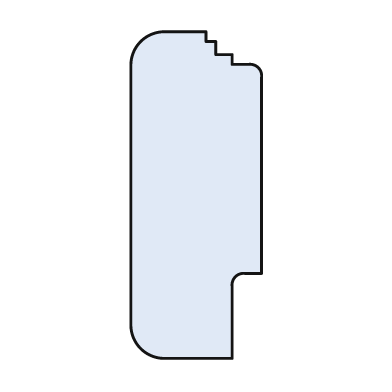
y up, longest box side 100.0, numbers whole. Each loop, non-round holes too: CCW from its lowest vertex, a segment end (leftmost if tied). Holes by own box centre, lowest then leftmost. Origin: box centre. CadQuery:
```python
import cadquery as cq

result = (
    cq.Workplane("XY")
    .moveTo(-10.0, -50.0)
    .lineTo(11.0, -50.0)
    .lineTo(11.0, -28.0)
    .threePointArc((12.0, -25.0), (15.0, -24.0))
    .lineTo(20.0, -24.0)
    .lineTo(20.0, 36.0)
    .threePointArc((19.0, 39.0), (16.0, 40.0))
    .lineTo(11.0, 40.0)
    .lineTo(11.0, 43.0)
    .lineTo(6.0, 43.0)
    .lineTo(6.0, 47.0)
    .lineTo(3.0, 47.0)
    .lineTo(3.0, 50.0)
    .lineTo(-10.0, 50.0)
    .threePointArc((-17.0, 47.0), (-20.0, 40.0))
    .lineTo(-20.0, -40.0)
    .threePointArc((-17.0, -47.0), (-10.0, -50.0))
    .close()
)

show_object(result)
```